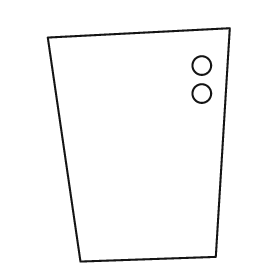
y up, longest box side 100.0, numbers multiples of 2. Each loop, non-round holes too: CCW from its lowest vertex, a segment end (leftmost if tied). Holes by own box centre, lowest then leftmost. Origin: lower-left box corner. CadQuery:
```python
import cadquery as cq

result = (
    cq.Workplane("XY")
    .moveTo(14.0, 0.0)
    .lineTo(72.0, 2.0)
    .lineTo(78.0, 100.0)
    .lineTo(0.0, 96.0)
    .close()
    .moveTo(66.0, 72.0)
    .circle(4.0)
    .moveTo(66.0, 84.0)
    .circle(4.0)
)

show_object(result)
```